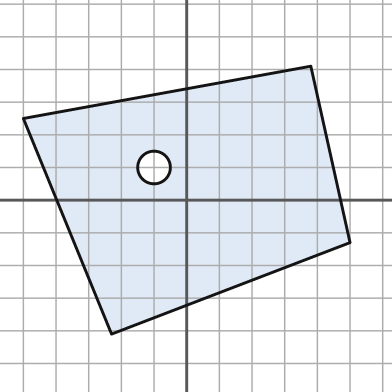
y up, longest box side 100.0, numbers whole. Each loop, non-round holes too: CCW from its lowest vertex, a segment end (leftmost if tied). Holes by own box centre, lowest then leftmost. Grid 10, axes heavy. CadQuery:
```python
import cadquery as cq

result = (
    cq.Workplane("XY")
    .moveTo(-23.0, -41.0)
    .lineTo(50.0, -13.0)
    .lineTo(38.0, 41.0)
    .lineTo(-50.0, 25.0)
    .close()
    .moveTo(-10.0, 10.0)
    .circle(5.0)
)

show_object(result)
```